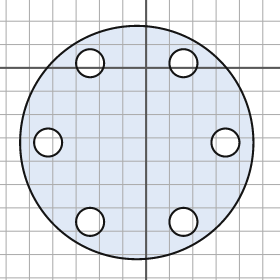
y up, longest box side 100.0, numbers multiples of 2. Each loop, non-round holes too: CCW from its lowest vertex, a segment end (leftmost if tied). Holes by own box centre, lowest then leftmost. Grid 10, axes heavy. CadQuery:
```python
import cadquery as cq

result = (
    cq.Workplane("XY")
    .moveTo(-4.0, -32.0)
    .circle(50.0)
    .moveTo(-24.0, -66.0)
    .circle(6.0)
    .moveTo(16.0, -66.0)
    .circle(6.0)
    .moveTo(-42.0, -32.0)
    .circle(6.0)
    .moveTo(34.0, -32.0)
    .circle(6.0)
    .moveTo(-24.0, 2.0)
    .circle(6.0)
    .moveTo(16.0, 2.0)
    .circle(6.0)
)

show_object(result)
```